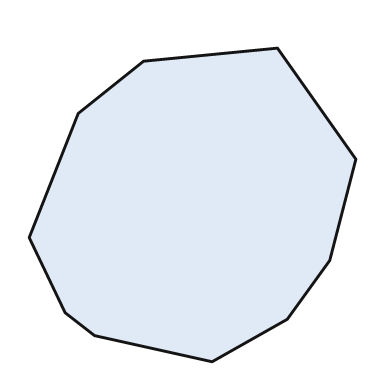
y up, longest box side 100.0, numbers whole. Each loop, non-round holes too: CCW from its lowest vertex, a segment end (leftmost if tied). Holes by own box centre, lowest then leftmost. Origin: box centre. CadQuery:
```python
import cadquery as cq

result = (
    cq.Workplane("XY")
    .moveTo(6.0, -48.0)
    .lineTo(29.0, -35.0)
    .lineTo(42.0, -17.0)
    .lineTo(50.0, 14.0)
    .lineTo(26.0, 48.0)
    .lineTo(-15.0, 44.0)
    .lineTo(-35.0, 28.0)
    .lineTo(-50.0, -10.0)
    .lineTo(-39.0, -33.0)
    .lineTo(-30.0, -40.0)
    .close()
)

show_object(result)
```